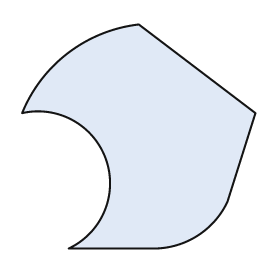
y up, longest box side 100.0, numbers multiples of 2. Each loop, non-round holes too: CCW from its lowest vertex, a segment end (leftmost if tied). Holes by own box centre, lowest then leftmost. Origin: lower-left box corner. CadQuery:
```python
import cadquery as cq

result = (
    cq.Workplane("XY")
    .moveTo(20.0, 0.0)
    .lineTo(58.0, 0.0)
    .threePointArc((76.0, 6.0), (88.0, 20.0))
    .lineTo(100.0, 58.0)
    .lineTo(50.0, 96.0)
    .threePointArc((20.0, 84.0), (0.0, 58.0))
    .threePointArc((36.0, 38.0), (20.0, 0.0))
    .close()
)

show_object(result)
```